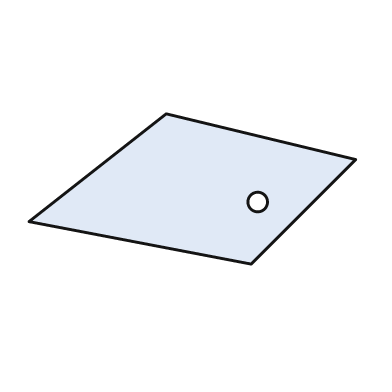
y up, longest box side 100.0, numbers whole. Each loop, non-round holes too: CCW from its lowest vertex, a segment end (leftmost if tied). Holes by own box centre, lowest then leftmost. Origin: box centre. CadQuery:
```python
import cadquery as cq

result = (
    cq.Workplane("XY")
    .moveTo(18.0, -23.0)
    .lineTo(50.0, 9.0)
    .lineTo(-8.0, 23.0)
    .lineTo(-50.0, -10.0)
    .close()
    .moveTo(20.0, -4.0)
    .circle(3.0)
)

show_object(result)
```